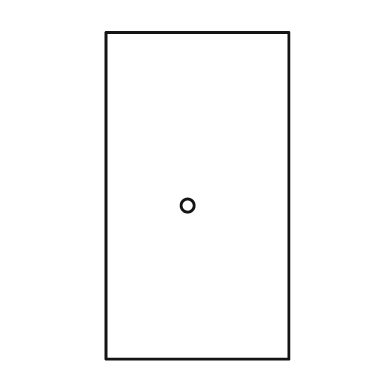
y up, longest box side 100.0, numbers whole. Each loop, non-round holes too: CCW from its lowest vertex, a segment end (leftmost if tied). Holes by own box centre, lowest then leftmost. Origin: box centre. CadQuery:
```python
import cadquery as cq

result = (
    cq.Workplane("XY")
    .moveTo(-28.0, -50.0)
    .lineTo(28.0, -50.0)
    .lineTo(28.0, 50.0)
    .lineTo(-28.0, 50.0)
    .close()
    .moveTo(-3.0, -3.0)
    .circle(2.0)
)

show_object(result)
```